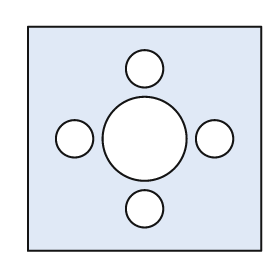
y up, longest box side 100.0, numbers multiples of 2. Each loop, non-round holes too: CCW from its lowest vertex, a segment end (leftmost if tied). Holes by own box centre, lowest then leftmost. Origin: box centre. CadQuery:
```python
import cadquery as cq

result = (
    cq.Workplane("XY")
    .moveTo(-50.0, -48.0)
    .lineTo(50.0, -48.0)
    .lineTo(50.0, 48.0)
    .lineTo(-50.0, 48.0)
    .close()
    .moveTo(0.0, -30.0)
    .circle(8.0)
    .moveTo(-30.0, 0.0)
    .circle(8.0)
    .moveTo(0.0, 0.0)
    .circle(18.0)
    .moveTo(30.0, 0.0)
    .circle(8.0)
    .moveTo(0.0, 30.0)
    .circle(8.0)
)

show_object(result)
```